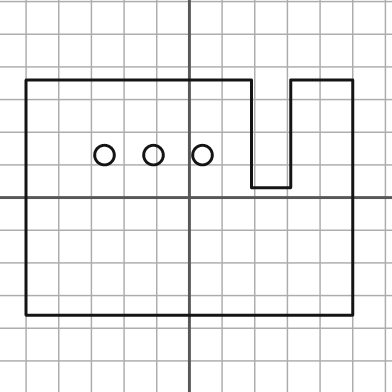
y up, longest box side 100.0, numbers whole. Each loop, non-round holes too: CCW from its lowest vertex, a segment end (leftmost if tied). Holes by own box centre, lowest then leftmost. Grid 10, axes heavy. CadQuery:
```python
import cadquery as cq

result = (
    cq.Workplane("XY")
    .moveTo(-50.0, -36.0)
    .lineTo(50.0, -36.0)
    .lineTo(50.0, 36.0)
    .lineTo(31.0, 36.0)
    .lineTo(31.0, 3.0)
    .lineTo(19.0, 3.0)
    .lineTo(19.0, 36.0)
    .lineTo(-50.0, 36.0)
    .close()
    .moveTo(-26.0, 13.0)
    .circle(3.0)
    .moveTo(-11.0, 13.0)
    .circle(3.0)
    .moveTo(4.0, 13.0)
    .circle(3.0)
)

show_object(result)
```